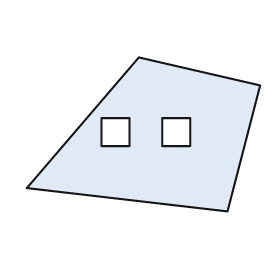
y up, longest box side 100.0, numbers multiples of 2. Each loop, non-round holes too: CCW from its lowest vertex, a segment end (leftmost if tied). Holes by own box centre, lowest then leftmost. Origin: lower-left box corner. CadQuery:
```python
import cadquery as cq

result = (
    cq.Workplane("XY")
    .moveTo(86.0, 0.0)
    .lineTo(100.0, 54.0)
    .lineTo(48.0, 66.0)
    .lineTo(0.0, 10.0)
    .close()
    .moveTo(32.0, 28.0)
    .lineTo(44.0, 28.0)
    .lineTo(44.0, 40.0)
    .lineTo(32.0, 40.0)
    .close()
    .moveTo(58.0, 28.0)
    .lineTo(70.0, 28.0)
    .lineTo(70.0, 40.0)
    .lineTo(58.0, 40.0)
    .close()
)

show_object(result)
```